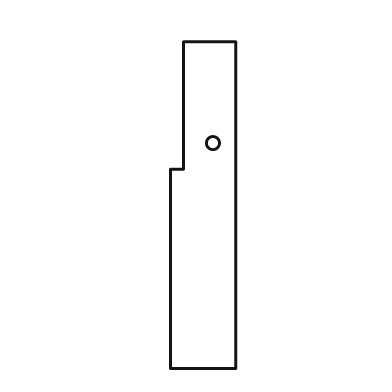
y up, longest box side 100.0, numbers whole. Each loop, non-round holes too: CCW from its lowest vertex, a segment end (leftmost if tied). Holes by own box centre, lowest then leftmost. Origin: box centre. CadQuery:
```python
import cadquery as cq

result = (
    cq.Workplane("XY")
    .moveTo(-10.0, -50.0)
    .lineTo(10.0, -50.0)
    .lineTo(10.0, 50.0)
    .lineTo(-6.0, 50.0)
    .lineTo(-6.0, 11.0)
    .lineTo(-10.0, 11.0)
    .close()
    .moveTo(3.0, 19.0)
    .circle(2.0)
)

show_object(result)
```